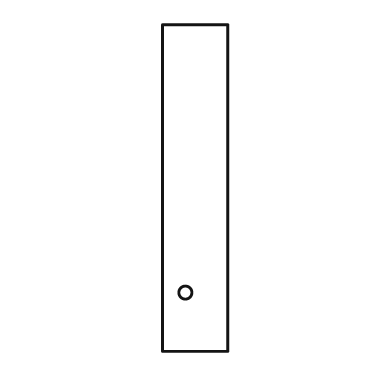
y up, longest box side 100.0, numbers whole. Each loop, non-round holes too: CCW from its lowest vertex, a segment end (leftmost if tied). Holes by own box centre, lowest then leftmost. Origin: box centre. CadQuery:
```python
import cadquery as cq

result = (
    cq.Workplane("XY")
    .moveTo(-10.0, -50.0)
    .lineTo(10.0, -50.0)
    .lineTo(10.0, 50.0)
    .lineTo(-10.0, 50.0)
    .close()
    .moveTo(-3.0, -32.0)
    .circle(2.0)
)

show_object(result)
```